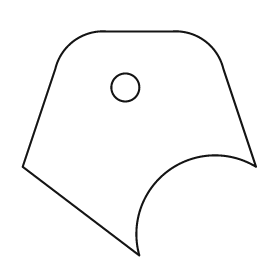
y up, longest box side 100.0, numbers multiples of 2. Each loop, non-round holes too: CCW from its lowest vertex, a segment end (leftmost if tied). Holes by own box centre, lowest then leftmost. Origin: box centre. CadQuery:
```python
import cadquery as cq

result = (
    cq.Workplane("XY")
    .moveTo(0.0, -48.0)
    .threePointArc((12.0, -12.0), (50.0, -10.0))
    .lineTo(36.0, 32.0)
    .threePointArc((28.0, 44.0), (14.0, 48.0))
    .lineTo(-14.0, 48.0)
    .threePointArc((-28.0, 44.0), (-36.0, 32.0))
    .lineTo(-50.0, -10.0)
    .close()
    .moveTo(-6.0, 24.0)
    .circle(6.0)
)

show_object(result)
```